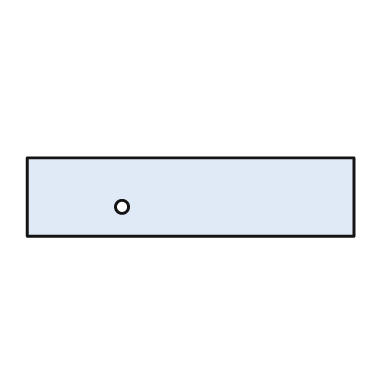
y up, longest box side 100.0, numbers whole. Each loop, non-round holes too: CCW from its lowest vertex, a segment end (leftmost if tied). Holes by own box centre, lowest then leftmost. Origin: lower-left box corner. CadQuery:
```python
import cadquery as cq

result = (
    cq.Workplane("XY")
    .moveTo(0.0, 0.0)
    .lineTo(100.0, 0.0)
    .lineTo(100.0, 24.0)
    .lineTo(0.0, 24.0)
    .close()
    .moveTo(29.0, 9.0)
    .circle(2.0)
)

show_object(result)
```